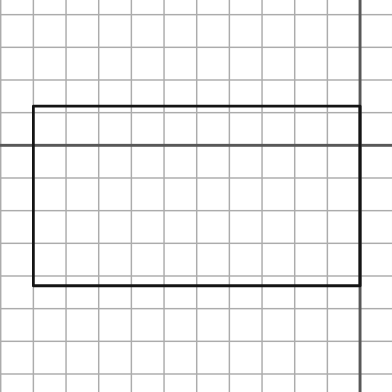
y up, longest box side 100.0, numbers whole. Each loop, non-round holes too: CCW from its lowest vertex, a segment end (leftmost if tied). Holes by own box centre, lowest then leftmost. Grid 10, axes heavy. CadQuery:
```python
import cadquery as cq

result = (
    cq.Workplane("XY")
    .moveTo(-100.0, -43.0)
    .lineTo(0.0, -43.0)
    .lineTo(0.0, 12.0)
    .lineTo(-100.0, 12.0)
    .close()
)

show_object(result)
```